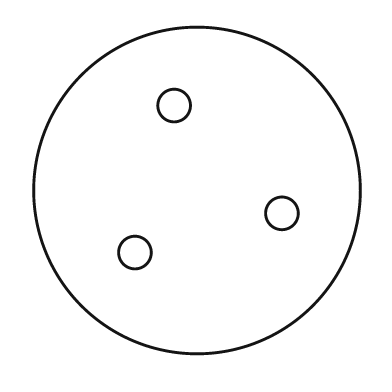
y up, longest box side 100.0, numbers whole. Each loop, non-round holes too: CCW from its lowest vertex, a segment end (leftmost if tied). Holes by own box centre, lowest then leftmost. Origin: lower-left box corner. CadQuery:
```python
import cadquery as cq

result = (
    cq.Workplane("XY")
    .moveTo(50.0, 50.0)
    .circle(50.0)
    .moveTo(31.0, 31.0)
    .circle(5.0)
    .moveTo(76.0, 43.0)
    .circle(5.0)
    .moveTo(43.0, 76.0)
    .circle(5.0)
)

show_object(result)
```